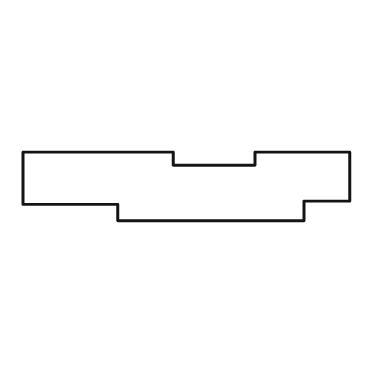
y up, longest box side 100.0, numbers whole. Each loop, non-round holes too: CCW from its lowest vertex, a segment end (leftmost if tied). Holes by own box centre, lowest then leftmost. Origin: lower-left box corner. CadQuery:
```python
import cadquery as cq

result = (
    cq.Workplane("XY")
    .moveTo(29.0, 0.0)
    .lineTo(86.0, 0.0)
    .lineTo(86.0, 6.0)
    .lineTo(100.0, 6.0)
    .lineTo(100.0, 21.0)
    .lineTo(71.0, 21.0)
    .lineTo(71.0, 17.0)
    .lineTo(46.0, 17.0)
    .lineTo(46.0, 21.0)
    .lineTo(0.0, 21.0)
    .lineTo(0.0, 5.0)
    .lineTo(29.0, 5.0)
    .close()
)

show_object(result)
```